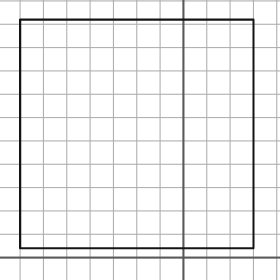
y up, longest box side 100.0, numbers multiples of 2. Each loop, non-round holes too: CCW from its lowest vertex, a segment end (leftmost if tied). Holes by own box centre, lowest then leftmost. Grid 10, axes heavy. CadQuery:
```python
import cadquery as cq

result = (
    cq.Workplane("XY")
    .moveTo(-70.0, 4.0)
    .lineTo(30.0, 4.0)
    .lineTo(30.0, 102.0)
    .lineTo(-70.0, 102.0)
    .close()
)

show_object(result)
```